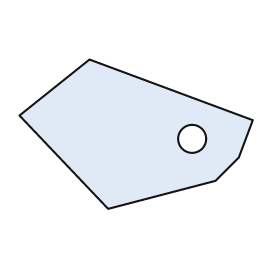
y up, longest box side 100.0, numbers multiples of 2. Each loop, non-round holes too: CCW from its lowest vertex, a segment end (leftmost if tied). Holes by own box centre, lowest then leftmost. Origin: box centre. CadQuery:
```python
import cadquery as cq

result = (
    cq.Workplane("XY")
    .moveTo(-12.0, -32.0)
    .lineTo(34.0, -20.0)
    .lineTo(44.0, -10.0)
    .lineTo(50.0, 6.0)
    .lineTo(-20.0, 32.0)
    .lineTo(-50.0, 8.0)
    .close()
    .moveTo(24.0, -2.0)
    .circle(6.0)
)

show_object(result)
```